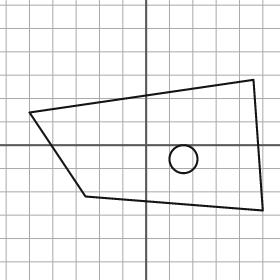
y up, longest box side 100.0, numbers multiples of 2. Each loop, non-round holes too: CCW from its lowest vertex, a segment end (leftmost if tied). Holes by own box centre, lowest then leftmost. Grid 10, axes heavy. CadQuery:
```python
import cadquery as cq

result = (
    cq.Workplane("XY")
    .moveTo(50.0, -28.0)
    .lineTo(46.0, 28.0)
    .lineTo(-50.0, 14.0)
    .lineTo(-26.0, -22.0)
    .close()
    .moveTo(16.0, -6.0)
    .circle(6.0)
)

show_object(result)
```